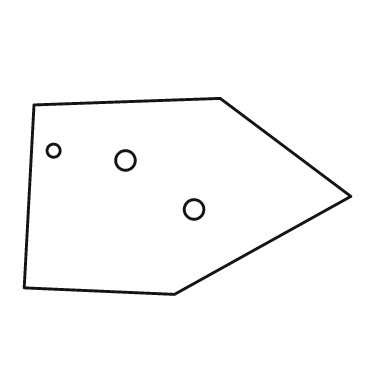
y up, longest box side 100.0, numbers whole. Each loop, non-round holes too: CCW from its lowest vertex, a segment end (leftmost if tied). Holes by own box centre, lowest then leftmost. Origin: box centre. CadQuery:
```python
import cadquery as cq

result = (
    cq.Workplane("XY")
    .moveTo(-4.0, -30.0)
    .lineTo(50.0, 0.0)
    .lineTo(10.0, 30.0)
    .lineTo(-47.0, 28.0)
    .lineTo(-50.0, -28.0)
    .close()
    .moveTo(2.0, -4.0)
    .circle(3.0)
    .moveTo(-19.0, 11.0)
    .circle(3.0)
    .moveTo(-41.0, 14.0)
    .circle(2.0)
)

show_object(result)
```